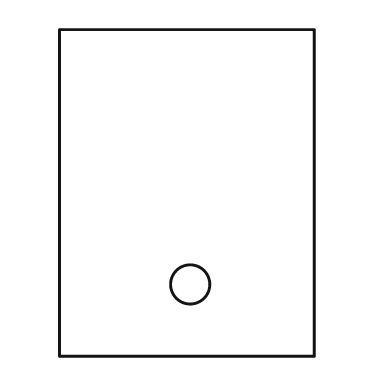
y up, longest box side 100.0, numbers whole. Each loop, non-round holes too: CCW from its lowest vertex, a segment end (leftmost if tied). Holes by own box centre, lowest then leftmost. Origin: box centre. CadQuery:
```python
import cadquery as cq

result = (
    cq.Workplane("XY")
    .moveTo(-39.0, -50.0)
    .lineTo(39.0, -50.0)
    .lineTo(39.0, 50.0)
    .lineTo(-39.0, 50.0)
    .close()
    .moveTo(1.0, -28.0)
    .circle(6.0)
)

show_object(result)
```